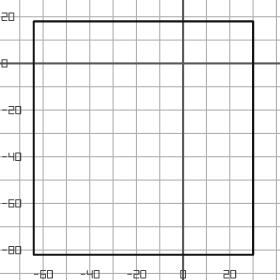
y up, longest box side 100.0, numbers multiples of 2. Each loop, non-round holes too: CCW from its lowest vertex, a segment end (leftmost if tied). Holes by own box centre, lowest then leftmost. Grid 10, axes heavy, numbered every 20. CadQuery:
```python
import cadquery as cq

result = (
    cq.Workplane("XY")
    .moveTo(-64.0, -82.0)
    .lineTo(30.0, -82.0)
    .lineTo(30.0, 18.0)
    .lineTo(-64.0, 18.0)
    .close()
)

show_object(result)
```